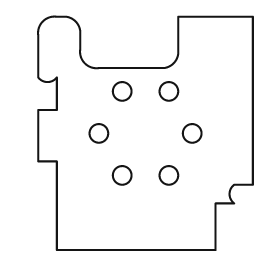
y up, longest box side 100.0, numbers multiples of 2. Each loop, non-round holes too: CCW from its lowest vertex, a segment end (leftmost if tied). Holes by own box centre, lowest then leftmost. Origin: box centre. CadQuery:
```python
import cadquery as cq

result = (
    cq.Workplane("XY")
    .moveTo(-38.0, -50.0)
    .lineTo(30.0, -50.0)
    .lineTo(30.0, -30.0)
    .lineTo(38.0, -30.0)
    .threePointArc((36.0, -26.0), (38.0, -22.0))
    .lineTo(46.0, -22.0)
    .lineTo(46.0, 50.0)
    .lineTo(14.0, 50.0)
    .lineTo(14.0, 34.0)
    .threePointArc((12.0, 30.0), (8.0, 28.0))
    .lineTo(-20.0, 28.0)
    .threePointArc((-26.0, 30.0), (-28.0, 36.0))
    .lineTo(-28.0, 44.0)
    .threePointArc((-30.0, 48.0), (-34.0, 50.0))
    .lineTo(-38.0, 50.0)
    .threePointArc((-44.0, 48.0), (-46.0, 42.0))
    .lineTo(-46.0, 24.0)
    .threePointArc((-42.0, 22.0), (-38.0, 24.0))
    .lineTo(-38.0, 10.0)
    .lineTo(-46.0, 10.0)
    .lineTo(-46.0, -12.0)
    .lineTo(-38.0, -12.0)
    .close()
    .moveTo(-10.0, -18.0)
    .circle(4.0)
    .moveTo(10.0, -18.0)
    .circle(4.0)
    .moveTo(-20.0, 0.0)
    .circle(4.0)
    .moveTo(20.0, 0.0)
    .circle(4.0)
    .moveTo(-10.0, 18.0)
    .circle(4.0)
    .moveTo(10.0, 18.0)
    .circle(4.0)
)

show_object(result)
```